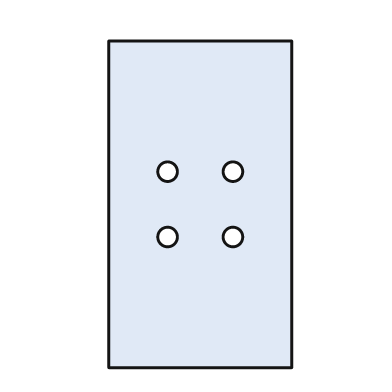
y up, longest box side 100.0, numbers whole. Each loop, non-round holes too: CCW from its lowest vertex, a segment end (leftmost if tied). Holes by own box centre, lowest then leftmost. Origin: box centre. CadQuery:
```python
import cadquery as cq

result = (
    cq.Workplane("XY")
    .moveTo(-28.0, -50.0)
    .lineTo(28.0, -50.0)
    .lineTo(28.0, 50.0)
    .lineTo(-28.0, 50.0)
    .close()
    .moveTo(-10.0, -10.0)
    .circle(3.0)
    .moveTo(10.0, -10.0)
    .circle(3.0)
    .moveTo(-10.0, 10.0)
    .circle(3.0)
    .moveTo(10.0, 10.0)
    .circle(3.0)
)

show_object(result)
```